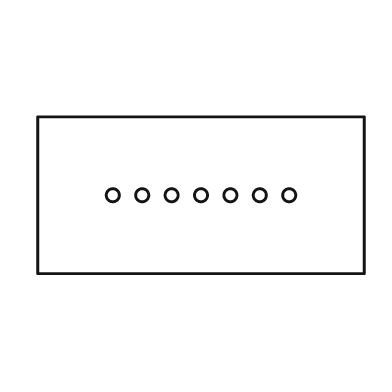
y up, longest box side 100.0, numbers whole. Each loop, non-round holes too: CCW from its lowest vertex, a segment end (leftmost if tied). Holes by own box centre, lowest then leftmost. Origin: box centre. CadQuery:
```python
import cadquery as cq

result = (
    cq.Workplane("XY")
    .moveTo(-50.0, -24.0)
    .lineTo(50.0, -24.0)
    .lineTo(50.0, 24.0)
    .lineTo(-50.0, 24.0)
    .close()
    .moveTo(-27.0, 0.0)
    .circle(2.0)
    .moveTo(-18.0, 0.0)
    .circle(2.0)
    .moveTo(-9.0, 0.0)
    .circle(2.0)
    .moveTo(0.0, 0.0)
    .circle(2.0)
    .moveTo(9.0, 0.0)
    .circle(2.0)
    .moveTo(18.0, 0.0)
    .circle(2.0)
    .moveTo(27.0, 0.0)
    .circle(2.0)
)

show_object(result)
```